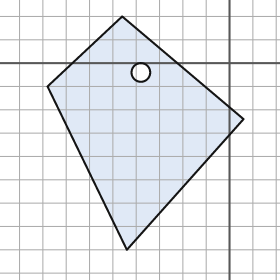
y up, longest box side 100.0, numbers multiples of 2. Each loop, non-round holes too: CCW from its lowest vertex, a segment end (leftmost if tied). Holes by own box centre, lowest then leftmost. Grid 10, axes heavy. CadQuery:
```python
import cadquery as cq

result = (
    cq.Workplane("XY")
    .moveTo(-44.0, -80.0)
    .lineTo(6.0, -24.0)
    .lineTo(-46.0, 20.0)
    .lineTo(-78.0, -10.0)
    .close()
    .moveTo(-38.0, -4.0)
    .circle(4.0)
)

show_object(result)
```